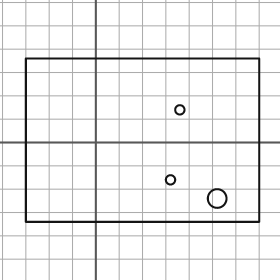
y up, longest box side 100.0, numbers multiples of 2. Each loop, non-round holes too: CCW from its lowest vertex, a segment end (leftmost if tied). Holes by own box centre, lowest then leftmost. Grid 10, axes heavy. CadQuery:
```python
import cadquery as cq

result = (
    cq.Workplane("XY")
    .moveTo(-30.0, -34.0)
    .lineTo(70.0, -34.0)
    .lineTo(70.0, 36.0)
    .lineTo(-30.0, 36.0)
    .close()
    .moveTo(52.0, -24.0)
    .circle(4.0)
    .moveTo(32.0, -16.0)
    .circle(2.0)
    .moveTo(36.0, 14.0)
    .circle(2.0)
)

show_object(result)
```